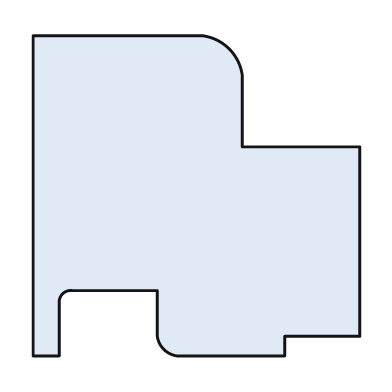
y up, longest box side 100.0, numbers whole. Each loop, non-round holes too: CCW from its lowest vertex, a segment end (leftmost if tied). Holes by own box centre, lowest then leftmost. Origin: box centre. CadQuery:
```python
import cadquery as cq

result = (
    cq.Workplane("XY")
    .moveTo(-50.0, -49.0)
    .lineTo(-42.0, -49.0)
    .lineTo(-42.0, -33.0)
    .threePointArc((-41.0, -30.0), (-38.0, -29.0))
    .lineTo(-12.0, -29.0)
    .lineTo(-12.0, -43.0)
    .threePointArc((-10.0, -47.0), (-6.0, -49.0))
    .lineTo(27.0, -49.0)
    .lineTo(27.0, -43.0)
    .lineTo(50.0, -43.0)
    .lineTo(50.0, 15.0)
    .lineTo(14.0, 15.0)
    .lineTo(14.0, 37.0)
    .threePointArc((10.0, 45.0), (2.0, 49.0))
    .lineTo(-50.0, 49.0)
    .close()
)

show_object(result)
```